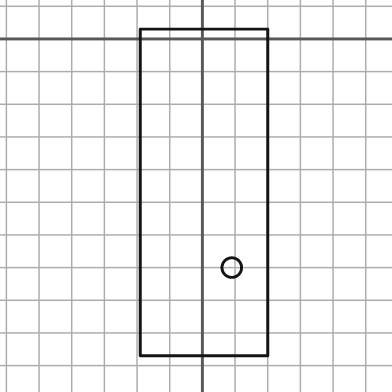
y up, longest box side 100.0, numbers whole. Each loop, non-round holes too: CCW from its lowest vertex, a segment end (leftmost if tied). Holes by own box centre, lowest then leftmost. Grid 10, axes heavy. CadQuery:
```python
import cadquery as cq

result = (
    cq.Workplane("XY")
    .moveTo(-19.0, -97.0)
    .lineTo(20.0, -97.0)
    .lineTo(20.0, 3.0)
    .lineTo(-19.0, 3.0)
    .close()
    .moveTo(9.0, -70.0)
    .circle(3.0)
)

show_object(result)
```